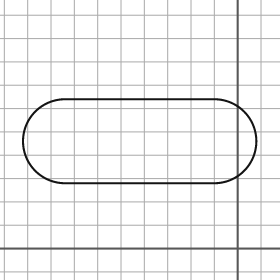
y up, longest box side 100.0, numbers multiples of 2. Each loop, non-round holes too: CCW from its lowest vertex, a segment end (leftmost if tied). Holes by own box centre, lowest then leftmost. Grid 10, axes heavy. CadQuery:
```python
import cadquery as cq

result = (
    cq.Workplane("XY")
    .moveTo(-74.0, 28.0)
    .lineTo(-10.0, 28.0)
    .threePointArc((8.0, 46.0), (-10.0, 64.0))
    .lineTo(-74.0, 64.0)
    .threePointArc((-92.0, 46.0), (-74.0, 28.0))
    .close()
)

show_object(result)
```